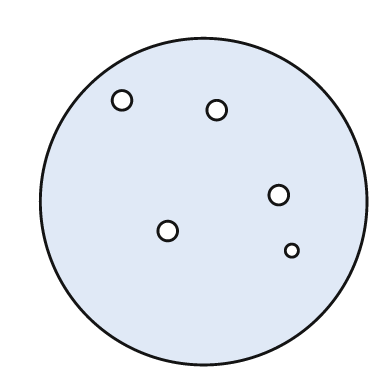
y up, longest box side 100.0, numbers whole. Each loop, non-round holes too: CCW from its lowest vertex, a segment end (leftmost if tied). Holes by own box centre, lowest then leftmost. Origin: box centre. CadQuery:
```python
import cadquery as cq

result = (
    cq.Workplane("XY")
    .moveTo(0.0, 0.0)
    .circle(50.0)
    .moveTo(27.0, -15.0)
    .circle(2.0)
    .moveTo(-11.0, -9.0)
    .circle(3.0)
    .moveTo(23.0, 2.0)
    .circle(3.0)
    .moveTo(4.0, 28.0)
    .circle(3.0)
    .moveTo(-25.0, 31.0)
    .circle(3.0)
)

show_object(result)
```